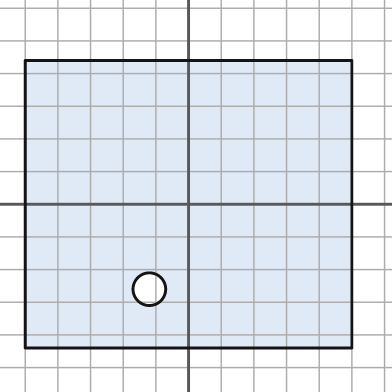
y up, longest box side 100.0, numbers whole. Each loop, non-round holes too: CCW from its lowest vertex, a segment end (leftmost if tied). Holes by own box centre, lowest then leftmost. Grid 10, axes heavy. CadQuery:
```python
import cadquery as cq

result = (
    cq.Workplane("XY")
    .moveTo(-50.0, -44.0)
    .lineTo(50.0, -44.0)
    .lineTo(50.0, 44.0)
    .lineTo(-50.0, 44.0)
    .close()
    .moveTo(-12.0, -26.0)
    .circle(5.0)
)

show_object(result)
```